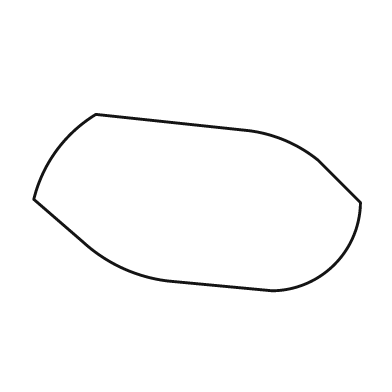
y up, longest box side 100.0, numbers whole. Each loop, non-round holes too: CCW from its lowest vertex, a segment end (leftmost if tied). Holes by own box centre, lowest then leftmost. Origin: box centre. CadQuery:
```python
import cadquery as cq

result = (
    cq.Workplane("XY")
    .moveTo(23.0, -27.0)
    .threePointArc((42.0, -19.0), (50.0, 0.0))
    .lineTo(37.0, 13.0)
    .threePointArc((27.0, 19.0), (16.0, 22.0))
    .lineTo(-31.0, 27.0)
    .threePointArc((-43.0, 16.0), (-50.0, 1.0))
    .lineTo(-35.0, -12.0)
    .threePointArc((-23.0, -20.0), (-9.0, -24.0))
    .close()
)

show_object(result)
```